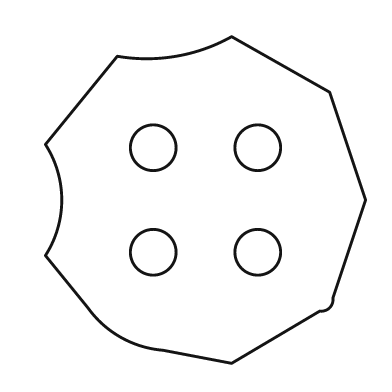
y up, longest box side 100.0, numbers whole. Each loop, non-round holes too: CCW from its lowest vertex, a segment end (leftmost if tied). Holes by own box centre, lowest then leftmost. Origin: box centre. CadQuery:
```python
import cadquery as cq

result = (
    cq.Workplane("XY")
    .moveTo(8.0, -50.0)
    .lineTo(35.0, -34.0)
    .threePointArc((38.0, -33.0), (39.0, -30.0))
    .lineTo(49.0, 0.0)
    .lineTo(38.0, 33.0)
    .lineTo(8.0, 50.0)
    .threePointArc((-9.0, 44.0), (-27.0, 44.0))
    .lineTo(-49.0, 17.0)
    .threePointArc((-44.0, 0.0), (-49.0, -17.0))
    .lineTo(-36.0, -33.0)
    .threePointArc((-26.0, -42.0), (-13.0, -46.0))
    .close()
    .moveTo(-16.0, -16.0)
    .circle(7.0)
    .moveTo(16.0, -16.0)
    .circle(7.0)
    .moveTo(-16.0, 16.0)
    .circle(7.0)
    .moveTo(16.0, 16.0)
    .circle(7.0)
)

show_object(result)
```